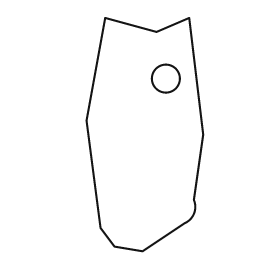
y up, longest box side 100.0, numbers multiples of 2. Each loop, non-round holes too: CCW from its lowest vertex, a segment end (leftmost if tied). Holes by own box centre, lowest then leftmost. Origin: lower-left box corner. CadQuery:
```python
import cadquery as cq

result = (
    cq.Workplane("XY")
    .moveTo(24.0, 0.0)
    .lineTo(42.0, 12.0)
    .threePointArc((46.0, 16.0), (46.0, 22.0))
    .lineTo(50.0, 50.0)
    .lineTo(44.0, 100.0)
    .lineTo(30.0, 94.0)
    .lineTo(8.0, 100.0)
    .lineTo(0.0, 56.0)
    .lineTo(6.0, 10.0)
    .lineTo(12.0, 2.0)
    .close()
    .moveTo(34.0, 74.0)
    .circle(6.0)
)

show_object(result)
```